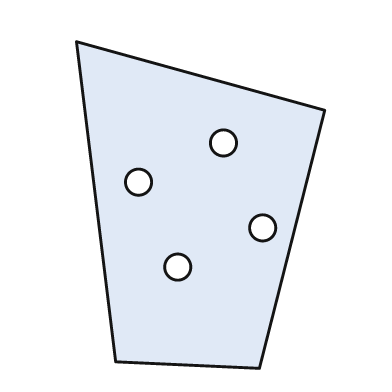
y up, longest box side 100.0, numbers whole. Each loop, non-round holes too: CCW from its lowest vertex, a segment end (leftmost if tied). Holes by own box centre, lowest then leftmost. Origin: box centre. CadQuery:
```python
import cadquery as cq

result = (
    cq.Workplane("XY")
    .moveTo(18.0, -50.0)
    .lineTo(38.0, 29.0)
    .lineTo(-38.0, 50.0)
    .lineTo(-26.0, -48.0)
    .close()
    .moveTo(-7.0, -19.0)
    .circle(4.0)
    .moveTo(19.0, -7.0)
    .circle(4.0)
    .moveTo(-19.0, 7.0)
    .circle(4.0)
    .moveTo(7.0, 19.0)
    .circle(4.0)
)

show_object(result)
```